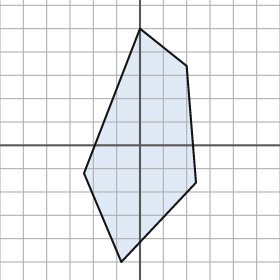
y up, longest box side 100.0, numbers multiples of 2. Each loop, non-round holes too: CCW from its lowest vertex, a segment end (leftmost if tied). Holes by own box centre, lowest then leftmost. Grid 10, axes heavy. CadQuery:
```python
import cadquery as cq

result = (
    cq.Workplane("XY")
    .moveTo(-8.0, -50.0)
    .lineTo(24.0, -16.0)
    .lineTo(20.0, 34.0)
    .lineTo(0.0, 50.0)
    .lineTo(-24.0, -12.0)
    .close()
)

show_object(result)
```